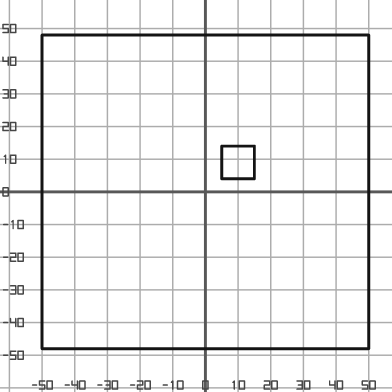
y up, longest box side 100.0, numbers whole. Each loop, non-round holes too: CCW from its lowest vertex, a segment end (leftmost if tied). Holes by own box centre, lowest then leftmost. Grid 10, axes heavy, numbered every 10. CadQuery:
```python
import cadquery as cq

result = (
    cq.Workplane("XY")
    .moveTo(-50.0, -48.0)
    .lineTo(50.0, -48.0)
    .lineTo(50.0, 48.0)
    .lineTo(-50.0, 48.0)
    .close()
    .moveTo(5.0, 4.0)
    .lineTo(15.0, 4.0)
    .lineTo(15.0, 14.0)
    .lineTo(5.0, 14.0)
    .close()
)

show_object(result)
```